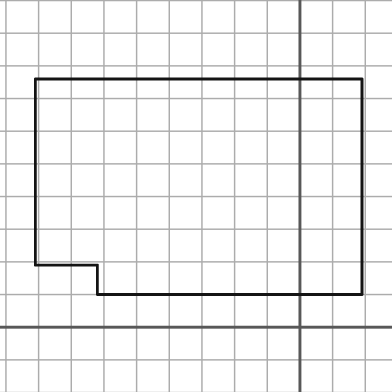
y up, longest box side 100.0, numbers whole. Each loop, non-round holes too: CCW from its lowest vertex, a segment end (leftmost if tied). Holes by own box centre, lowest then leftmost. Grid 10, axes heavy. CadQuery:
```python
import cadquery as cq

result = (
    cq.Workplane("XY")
    .moveTo(-62.0, 10.0)
    .lineTo(19.0, 10.0)
    .lineTo(19.0, 76.0)
    .lineTo(-81.0, 76.0)
    .lineTo(-81.0, 19.0)
    .lineTo(-62.0, 19.0)
    .close()
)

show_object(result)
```